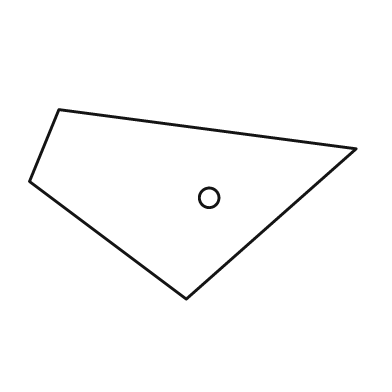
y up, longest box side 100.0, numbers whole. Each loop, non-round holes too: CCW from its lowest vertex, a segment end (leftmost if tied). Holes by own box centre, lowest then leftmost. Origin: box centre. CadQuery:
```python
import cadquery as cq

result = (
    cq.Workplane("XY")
    .moveTo(-2.0, -29.0)
    .lineTo(50.0, 17.0)
    .lineTo(-41.0, 29.0)
    .lineTo(-50.0, 7.0)
    .close()
    .moveTo(5.0, 2.0)
    .circle(3.0)
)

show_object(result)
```